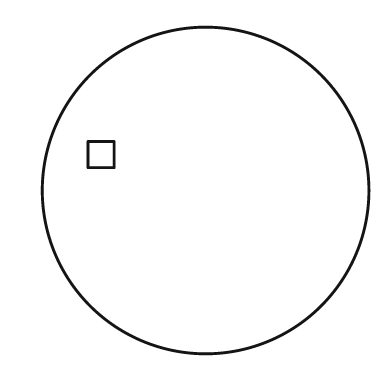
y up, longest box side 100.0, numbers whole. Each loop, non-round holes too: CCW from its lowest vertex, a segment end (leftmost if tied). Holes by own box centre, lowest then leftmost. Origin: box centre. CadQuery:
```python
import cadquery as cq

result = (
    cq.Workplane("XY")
    .moveTo(0.0, 0.0)
    .circle(50.0)
    .moveTo(-36.0, 7.0)
    .lineTo(-28.0, 7.0)
    .lineTo(-28.0, 15.0)
    .lineTo(-36.0, 15.0)
    .close()
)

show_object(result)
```